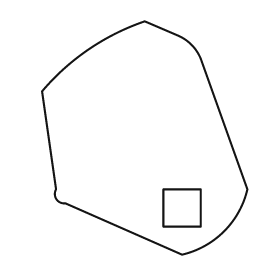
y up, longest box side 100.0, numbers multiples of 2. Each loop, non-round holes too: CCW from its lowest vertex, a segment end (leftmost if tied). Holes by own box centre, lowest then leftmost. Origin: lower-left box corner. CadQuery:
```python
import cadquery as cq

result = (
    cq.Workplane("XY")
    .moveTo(60.0, 0.0)
    .threePointArc((78.0, 10.0), (88.0, 28.0))
    .lineTo(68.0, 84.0)
    .threePointArc((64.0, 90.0), (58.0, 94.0))
    .lineTo(44.0, 100.0)
    .threePointArc((20.0, 88.0), (0.0, 70.0))
    .lineTo(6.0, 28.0)
    .threePointArc((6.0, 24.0), (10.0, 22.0))
    .close()
    .moveTo(52.0, 12.0)
    .lineTo(68.0, 12.0)
    .lineTo(68.0, 28.0)
    .lineTo(52.0, 28.0)
    .close()
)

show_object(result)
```